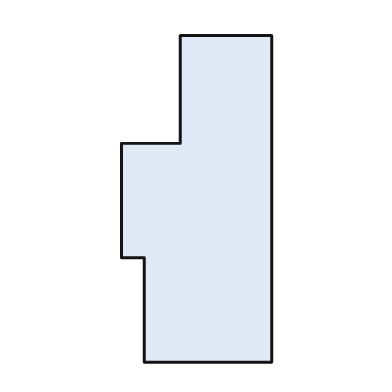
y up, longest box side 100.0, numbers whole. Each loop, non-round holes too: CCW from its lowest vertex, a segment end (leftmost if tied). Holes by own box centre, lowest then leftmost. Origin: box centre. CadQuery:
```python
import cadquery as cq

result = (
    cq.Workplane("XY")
    .moveTo(-16.0, -50.0)
    .lineTo(23.0, -50.0)
    .lineTo(23.0, 50.0)
    .lineTo(-5.0, 50.0)
    .lineTo(-5.0, 17.0)
    .lineTo(-23.0, 17.0)
    .lineTo(-23.0, -18.0)
    .lineTo(-16.0, -18.0)
    .close()
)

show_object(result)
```